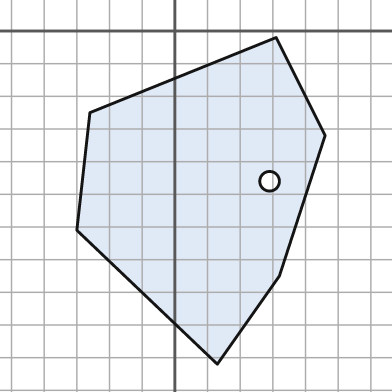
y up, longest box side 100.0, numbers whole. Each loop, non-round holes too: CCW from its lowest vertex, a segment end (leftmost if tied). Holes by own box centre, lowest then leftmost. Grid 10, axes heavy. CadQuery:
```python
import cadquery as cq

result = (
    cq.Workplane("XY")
    .moveTo(13.0, -102.0)
    .lineTo(32.0, -75.0)
    .lineTo(46.0, -32.0)
    .lineTo(31.0, -2.0)
    .lineTo(-26.0, -25.0)
    .lineTo(-30.0, -61.0)
    .close()
    .moveTo(29.0, -46.0)
    .circle(3.0)
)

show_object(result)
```